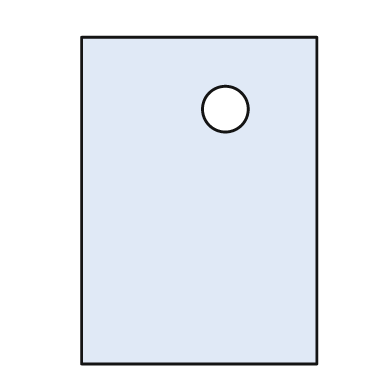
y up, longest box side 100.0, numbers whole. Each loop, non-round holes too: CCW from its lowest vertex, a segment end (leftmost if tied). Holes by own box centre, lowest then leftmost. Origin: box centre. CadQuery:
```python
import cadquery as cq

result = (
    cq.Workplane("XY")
    .moveTo(-36.0, -50.0)
    .lineTo(36.0, -50.0)
    .lineTo(36.0, 50.0)
    .lineTo(-36.0, 50.0)
    .close()
    .moveTo(8.0, 28.0)
    .circle(7.0)
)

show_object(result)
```